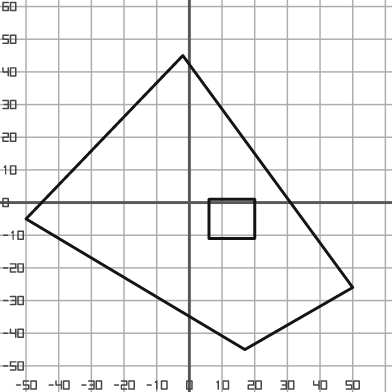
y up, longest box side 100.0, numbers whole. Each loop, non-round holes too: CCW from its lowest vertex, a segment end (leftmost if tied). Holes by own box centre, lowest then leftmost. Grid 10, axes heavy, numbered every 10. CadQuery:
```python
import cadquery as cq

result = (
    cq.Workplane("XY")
    .moveTo(17.0, -45.0)
    .lineTo(50.0, -26.0)
    .lineTo(-2.0, 45.0)
    .lineTo(-50.0, -5.0)
    .close()
    .moveTo(6.0, -11.0)
    .lineTo(20.0, -11.0)
    .lineTo(20.0, 1.0)
    .lineTo(6.0, 1.0)
    .close()
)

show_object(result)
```